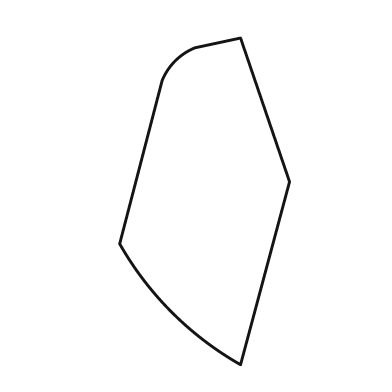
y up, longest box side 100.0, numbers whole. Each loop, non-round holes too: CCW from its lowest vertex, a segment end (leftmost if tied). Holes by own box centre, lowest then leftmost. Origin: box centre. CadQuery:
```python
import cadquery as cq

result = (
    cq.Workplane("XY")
    .moveTo(11.0, -50.0)
    .lineTo(26.0, 6.0)
    .lineTo(11.0, 50.0)
    .lineTo(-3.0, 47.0)
    .threePointArc((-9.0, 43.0), (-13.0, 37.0))
    .lineTo(-26.0, -13.0)
    .threePointArc((-10.0, -34.0), (11.0, -50.0))
    .close()
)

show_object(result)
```